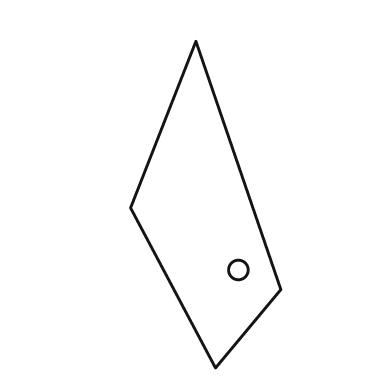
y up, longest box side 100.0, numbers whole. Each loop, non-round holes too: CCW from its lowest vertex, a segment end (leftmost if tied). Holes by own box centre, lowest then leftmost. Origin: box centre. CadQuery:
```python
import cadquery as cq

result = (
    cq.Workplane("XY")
    .moveTo(3.0, -50.0)
    .lineTo(23.0, -26.0)
    .lineTo(-3.0, 50.0)
    .lineTo(-23.0, -1.0)
    .close()
    .moveTo(10.0, -20.0)
    .circle(3.0)
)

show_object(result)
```